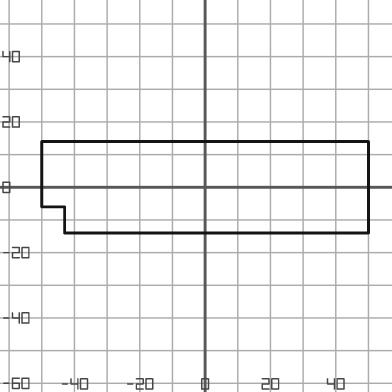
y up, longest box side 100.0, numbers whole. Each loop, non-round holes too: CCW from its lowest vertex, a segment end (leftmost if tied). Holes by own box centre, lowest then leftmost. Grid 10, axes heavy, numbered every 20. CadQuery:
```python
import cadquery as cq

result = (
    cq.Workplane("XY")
    .moveTo(-43.0, -14.0)
    .lineTo(50.0, -14.0)
    .lineTo(50.0, 14.0)
    .lineTo(-50.0, 14.0)
    .lineTo(-50.0, -6.0)
    .lineTo(-43.0, -6.0)
    .close()
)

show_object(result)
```